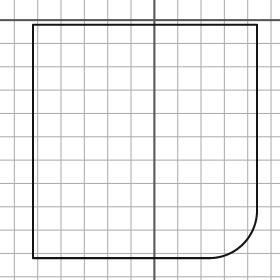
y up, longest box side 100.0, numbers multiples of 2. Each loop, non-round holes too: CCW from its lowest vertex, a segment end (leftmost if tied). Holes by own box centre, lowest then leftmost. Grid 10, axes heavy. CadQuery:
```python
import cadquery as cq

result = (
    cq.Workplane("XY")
    .moveTo(-52.0, -102.0)
    .lineTo(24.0, -102.0)
    .threePointArc((38.0, -96.0), (44.0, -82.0))
    .lineTo(44.0, -2.0)
    .lineTo(-52.0, -2.0)
    .close()
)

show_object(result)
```